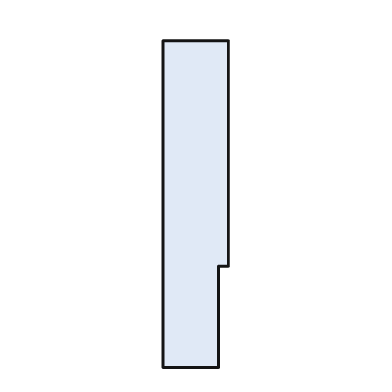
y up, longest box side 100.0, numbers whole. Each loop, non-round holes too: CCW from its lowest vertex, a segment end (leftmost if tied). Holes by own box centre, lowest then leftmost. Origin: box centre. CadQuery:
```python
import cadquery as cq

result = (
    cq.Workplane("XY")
    .moveTo(-10.0, -50.0)
    .lineTo(7.0, -50.0)
    .lineTo(7.0, -19.0)
    .lineTo(10.0, -19.0)
    .lineTo(10.0, 50.0)
    .lineTo(-10.0, 50.0)
    .close()
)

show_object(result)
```